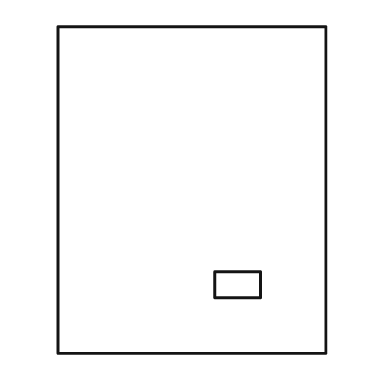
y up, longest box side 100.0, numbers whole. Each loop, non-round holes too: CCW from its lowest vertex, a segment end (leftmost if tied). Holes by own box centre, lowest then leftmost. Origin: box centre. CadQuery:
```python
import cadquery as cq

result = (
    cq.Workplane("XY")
    .moveTo(-41.0, -50.0)
    .lineTo(41.0, -50.0)
    .lineTo(41.0, 50.0)
    .lineTo(-41.0, 50.0)
    .close()
    .moveTo(7.0, -33.0)
    .lineTo(21.0, -33.0)
    .lineTo(21.0, -25.0)
    .lineTo(7.0, -25.0)
    .close()
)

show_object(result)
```